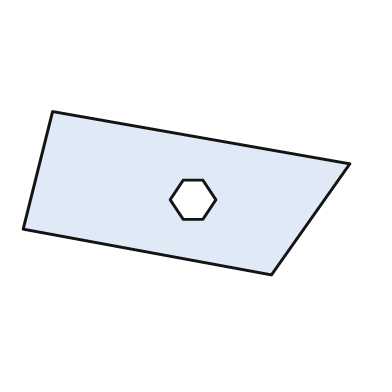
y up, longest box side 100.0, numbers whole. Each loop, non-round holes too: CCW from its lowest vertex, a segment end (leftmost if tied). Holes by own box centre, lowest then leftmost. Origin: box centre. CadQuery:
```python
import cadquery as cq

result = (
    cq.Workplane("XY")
    .moveTo(26.0, -25.0)
    .lineTo(50.0, 9.0)
    .lineTo(-41.0, 25.0)
    .lineTo(-50.0, -11.0)
    .close()
    .moveTo(-1.0, -8.0)
    .lineTo(5.0, -8.0)
    .lineTo(9.0, -2.0)
    .lineTo(5.0, 4.0)
    .lineTo(-1.0, 4.0)
    .lineTo(-5.0, -2.0)
    .close()
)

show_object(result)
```